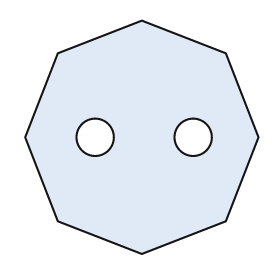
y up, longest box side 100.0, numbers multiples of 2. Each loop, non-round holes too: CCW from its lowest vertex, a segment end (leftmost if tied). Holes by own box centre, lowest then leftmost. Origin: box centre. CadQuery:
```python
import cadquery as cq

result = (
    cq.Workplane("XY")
    .moveTo(0.0, -50.0)
    .lineTo(36.0, -36.0)
    .lineTo(50.0, 0.0)
    .lineTo(36.0, 36.0)
    .lineTo(0.0, 50.0)
    .lineTo(-36.0, 36.0)
    .lineTo(-50.0, 0.0)
    .lineTo(-36.0, -36.0)
    .close()
    .moveTo(-20.0, 0.0)
    .circle(8.0)
    .moveTo(22.0, 0.0)
    .circle(8.0)
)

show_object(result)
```